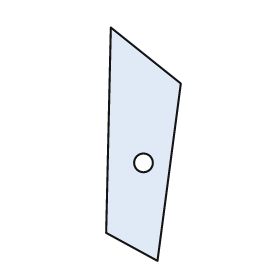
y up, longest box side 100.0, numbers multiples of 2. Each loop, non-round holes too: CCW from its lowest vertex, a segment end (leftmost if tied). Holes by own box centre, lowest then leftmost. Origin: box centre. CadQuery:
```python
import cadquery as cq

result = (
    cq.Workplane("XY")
    .moveTo(6.0, -50.0)
    .lineTo(16.0, 26.0)
    .lineTo(-14.0, 50.0)
    .lineTo(-16.0, -38.0)
    .close()
    .moveTo(0.0, -8.0)
    .circle(4.0)
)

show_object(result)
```